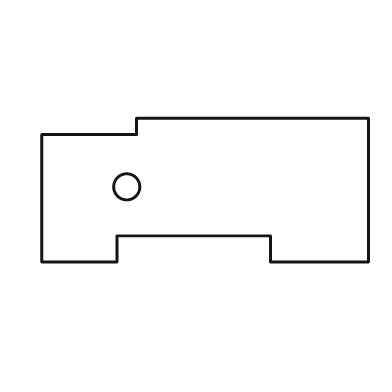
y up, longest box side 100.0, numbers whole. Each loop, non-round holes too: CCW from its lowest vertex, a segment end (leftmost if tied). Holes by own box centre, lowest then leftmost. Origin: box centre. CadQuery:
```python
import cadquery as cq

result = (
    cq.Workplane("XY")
    .moveTo(-50.0, -22.0)
    .lineTo(-27.0, -22.0)
    .lineTo(-27.0, -14.0)
    .lineTo(20.0, -14.0)
    .lineTo(20.0, -22.0)
    .lineTo(50.0, -22.0)
    .lineTo(50.0, 22.0)
    .lineTo(-21.0, 22.0)
    .lineTo(-21.0, 17.0)
    .lineTo(-50.0, 17.0)
    .close()
    .moveTo(-24.0, 1.0)
    .circle(4.0)
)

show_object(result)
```